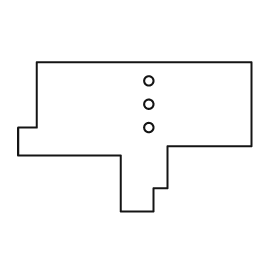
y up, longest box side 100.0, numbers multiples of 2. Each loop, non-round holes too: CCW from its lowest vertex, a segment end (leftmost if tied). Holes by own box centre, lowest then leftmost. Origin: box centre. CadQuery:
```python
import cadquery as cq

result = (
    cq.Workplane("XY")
    .moveTo(-6.0, -32.0)
    .lineTo(8.0, -32.0)
    .lineTo(8.0, -22.0)
    .lineTo(14.0, -22.0)
    .lineTo(14.0, -4.0)
    .lineTo(50.0, -4.0)
    .lineTo(50.0, 32.0)
    .lineTo(-42.0, 32.0)
    .lineTo(-42.0, 4.0)
    .lineTo(-50.0, 4.0)
    .lineTo(-50.0, -8.0)
    .lineTo(-6.0, -8.0)
    .close()
    .moveTo(6.0, 4.0)
    .circle(2.0)
    .moveTo(6.0, 14.0)
    .circle(2.0)
    .moveTo(6.0, 24.0)
    .circle(2.0)
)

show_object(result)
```